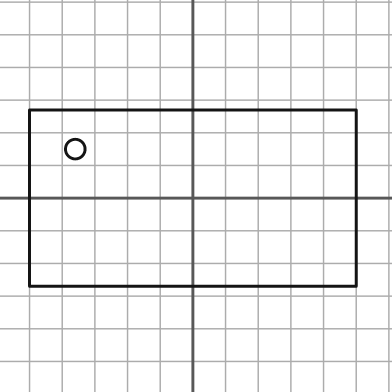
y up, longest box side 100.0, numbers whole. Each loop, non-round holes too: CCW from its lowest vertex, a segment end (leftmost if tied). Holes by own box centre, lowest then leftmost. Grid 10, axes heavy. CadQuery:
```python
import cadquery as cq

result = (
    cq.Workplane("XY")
    .moveTo(-50.0, -27.0)
    .lineTo(50.0, -27.0)
    .lineTo(50.0, 27.0)
    .lineTo(-50.0, 27.0)
    .close()
    .moveTo(-36.0, 15.0)
    .circle(3.0)
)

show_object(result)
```